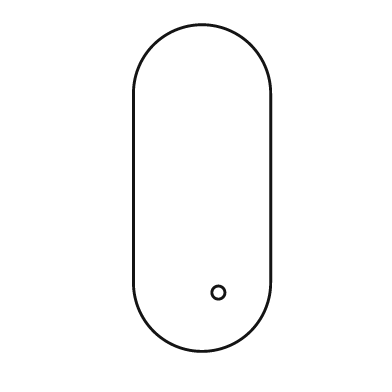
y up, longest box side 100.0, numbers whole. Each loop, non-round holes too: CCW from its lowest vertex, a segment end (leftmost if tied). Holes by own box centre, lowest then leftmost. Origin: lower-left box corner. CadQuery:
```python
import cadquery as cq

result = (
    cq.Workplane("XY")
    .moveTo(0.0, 21.0)
    .threePointArc((21.0, 0.0), (42.0, 21.0))
    .lineTo(42.0, 79.0)
    .threePointArc((21.0, 100.0), (0.0, 79.0))
    .close()
    .moveTo(26.0, 18.0)
    .circle(2.0)
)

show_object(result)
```